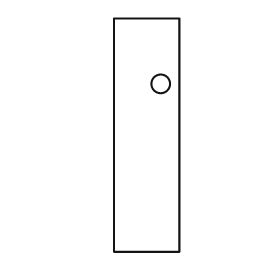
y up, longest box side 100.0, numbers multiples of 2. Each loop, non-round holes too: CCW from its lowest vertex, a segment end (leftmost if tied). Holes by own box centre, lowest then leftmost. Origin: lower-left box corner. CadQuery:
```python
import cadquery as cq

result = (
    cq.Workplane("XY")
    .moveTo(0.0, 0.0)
    .lineTo(28.0, 0.0)
    .lineTo(28.0, 100.0)
    .lineTo(0.0, 100.0)
    .close()
    .moveTo(20.0, 72.0)
    .circle(4.0)
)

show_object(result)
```